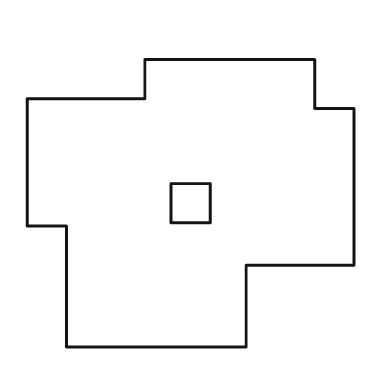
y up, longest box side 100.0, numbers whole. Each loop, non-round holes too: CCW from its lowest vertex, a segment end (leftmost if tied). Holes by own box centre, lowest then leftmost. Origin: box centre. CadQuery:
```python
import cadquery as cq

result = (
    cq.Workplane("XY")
    .moveTo(-38.0, -44.0)
    .lineTo(17.0, -44.0)
    .lineTo(17.0, -19.0)
    .lineTo(50.0, -19.0)
    .lineTo(50.0, 29.0)
    .lineTo(38.0, 29.0)
    .lineTo(38.0, 44.0)
    .lineTo(-14.0, 44.0)
    .lineTo(-14.0, 32.0)
    .lineTo(-50.0, 32.0)
    .lineTo(-50.0, -7.0)
    .lineTo(-38.0, -7.0)
    .close()
    .moveTo(-6.0, -6.0)
    .lineTo(6.0, -6.0)
    .lineTo(6.0, 6.0)
    .lineTo(-6.0, 6.0)
    .close()
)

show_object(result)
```